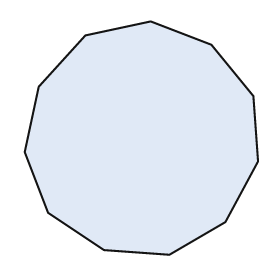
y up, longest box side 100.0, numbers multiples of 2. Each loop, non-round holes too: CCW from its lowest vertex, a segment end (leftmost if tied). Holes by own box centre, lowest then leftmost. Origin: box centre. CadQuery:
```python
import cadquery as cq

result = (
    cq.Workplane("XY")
    .moveTo(12.0, -50.0)
    .lineTo(36.0, -36.0)
    .lineTo(50.0, -10.0)
    .lineTo(48.0, 18.0)
    .lineTo(30.0, 40.0)
    .lineTo(4.0, 50.0)
    .lineTo(-24.0, 44.0)
    .lineTo(-44.0, 22.0)
    .lineTo(-50.0, -6.0)
    .lineTo(-40.0, -32.0)
    .lineTo(-16.0, -48.0)
    .close()
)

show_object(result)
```